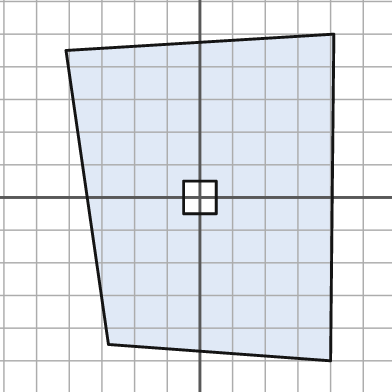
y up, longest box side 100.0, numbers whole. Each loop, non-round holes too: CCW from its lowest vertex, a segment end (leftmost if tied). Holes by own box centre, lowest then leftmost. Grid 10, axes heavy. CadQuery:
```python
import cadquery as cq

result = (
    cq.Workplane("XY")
    .moveTo(40.0, -50.0)
    .lineTo(41.0, 50.0)
    .lineTo(-41.0, 45.0)
    .lineTo(-28.0, -45.0)
    .close()
    .moveTo(-5.0, -5.0)
    .lineTo(5.0, -5.0)
    .lineTo(5.0, 5.0)
    .lineTo(-5.0, 5.0)
    .close()
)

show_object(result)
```